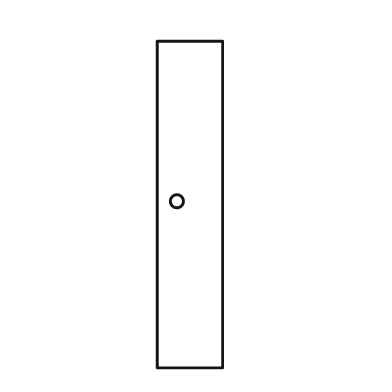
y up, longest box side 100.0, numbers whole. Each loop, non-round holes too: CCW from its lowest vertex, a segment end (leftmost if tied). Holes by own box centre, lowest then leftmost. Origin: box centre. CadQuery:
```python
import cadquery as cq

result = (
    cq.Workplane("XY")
    .moveTo(-10.0, -50.0)
    .lineTo(10.0, -50.0)
    .lineTo(10.0, 50.0)
    .lineTo(-10.0, 50.0)
    .close()
    .moveTo(-4.0, 1.0)
    .circle(2.0)
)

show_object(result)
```